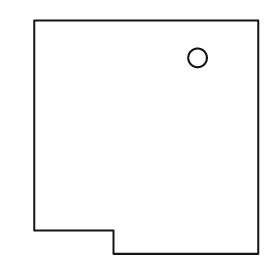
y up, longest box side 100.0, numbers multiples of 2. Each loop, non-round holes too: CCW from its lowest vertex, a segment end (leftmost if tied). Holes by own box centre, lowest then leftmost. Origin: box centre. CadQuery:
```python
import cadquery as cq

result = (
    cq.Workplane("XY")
    .moveTo(-14.0, -50.0)
    .lineTo(48.0, -50.0)
    .lineTo(48.0, 50.0)
    .lineTo(-48.0, 50.0)
    .lineTo(-48.0, -40.0)
    .lineTo(-14.0, -40.0)
    .close()
    .moveTo(22.0, 34.0)
    .circle(4.0)
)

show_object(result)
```